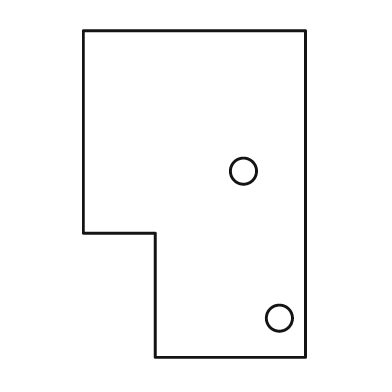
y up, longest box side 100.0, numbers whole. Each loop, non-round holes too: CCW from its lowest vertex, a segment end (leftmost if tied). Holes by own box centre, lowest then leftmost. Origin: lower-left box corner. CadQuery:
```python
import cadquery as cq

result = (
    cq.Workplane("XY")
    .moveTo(22.0, 0.0)
    .lineTo(68.0, 0.0)
    .lineTo(68.0, 100.0)
    .lineTo(0.0, 100.0)
    .lineTo(0.0, 38.0)
    .lineTo(22.0, 38.0)
    .close()
    .moveTo(60.0, 12.0)
    .circle(4.0)
    .moveTo(49.0, 57.0)
    .circle(4.0)
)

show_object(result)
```